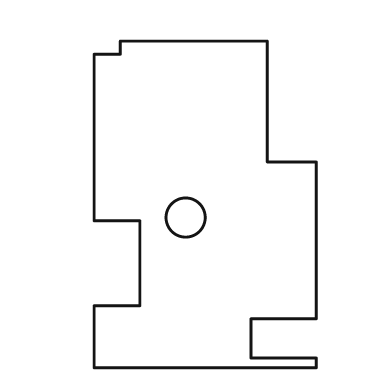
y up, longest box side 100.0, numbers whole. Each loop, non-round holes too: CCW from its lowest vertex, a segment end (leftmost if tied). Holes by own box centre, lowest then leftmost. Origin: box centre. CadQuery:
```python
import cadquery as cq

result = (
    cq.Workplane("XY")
    .moveTo(-34.0, -50.0)
    .lineTo(34.0, -50.0)
    .lineTo(34.0, -47.0)
    .lineTo(14.0, -47.0)
    .lineTo(14.0, -35.0)
    .lineTo(34.0, -35.0)
    .lineTo(34.0, 13.0)
    .lineTo(19.0, 13.0)
    .lineTo(19.0, 50.0)
    .lineTo(-26.0, 50.0)
    .lineTo(-26.0, 46.0)
    .lineTo(-34.0, 46.0)
    .lineTo(-34.0, -5.0)
    .lineTo(-20.0, -5.0)
    .lineTo(-20.0, -31.0)
    .lineTo(-34.0, -31.0)
    .close()
    .moveTo(-6.0, -4.0)
    .circle(6.0)
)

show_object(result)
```